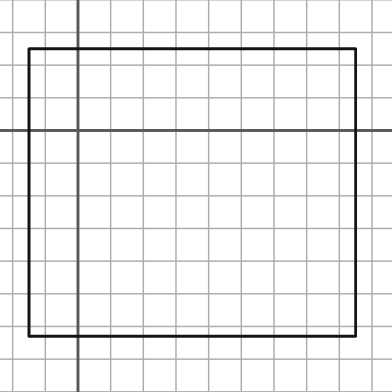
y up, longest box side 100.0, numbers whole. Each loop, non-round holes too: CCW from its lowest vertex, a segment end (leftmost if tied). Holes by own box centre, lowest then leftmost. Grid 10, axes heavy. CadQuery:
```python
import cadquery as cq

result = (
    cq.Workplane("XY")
    .moveTo(-15.0, -63.0)
    .lineTo(85.0, -63.0)
    .lineTo(85.0, 25.0)
    .lineTo(-15.0, 25.0)
    .close()
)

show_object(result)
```